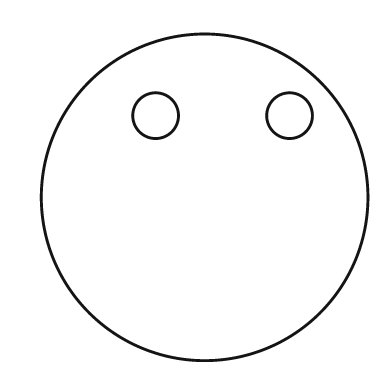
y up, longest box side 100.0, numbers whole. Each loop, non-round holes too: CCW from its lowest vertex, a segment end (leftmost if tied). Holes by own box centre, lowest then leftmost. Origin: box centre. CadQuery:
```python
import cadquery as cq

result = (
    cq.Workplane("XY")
    .moveTo(0.0, 0.0)
    .circle(50.0)
    .moveTo(-15.0, 25.0)
    .circle(7.0)
    .moveTo(26.0, 25.0)
    .circle(7.0)
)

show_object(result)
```